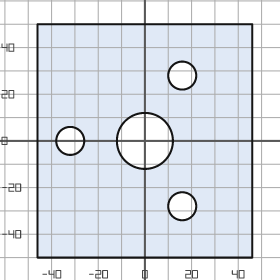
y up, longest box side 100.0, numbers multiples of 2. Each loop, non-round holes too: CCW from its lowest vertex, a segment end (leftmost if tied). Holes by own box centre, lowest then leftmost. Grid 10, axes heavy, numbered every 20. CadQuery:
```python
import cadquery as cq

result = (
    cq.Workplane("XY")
    .moveTo(-46.0, -50.0)
    .lineTo(46.0, -50.0)
    .lineTo(46.0, 50.0)
    .lineTo(-46.0, 50.0)
    .close()
    .moveTo(16.0, -28.0)
    .circle(6.0)
    .moveTo(-32.0, 0.0)
    .circle(6.0)
    .moveTo(0.0, 0.0)
    .circle(12.0)
    .moveTo(16.0, 28.0)
    .circle(6.0)
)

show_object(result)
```